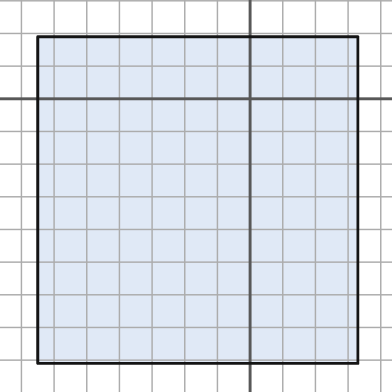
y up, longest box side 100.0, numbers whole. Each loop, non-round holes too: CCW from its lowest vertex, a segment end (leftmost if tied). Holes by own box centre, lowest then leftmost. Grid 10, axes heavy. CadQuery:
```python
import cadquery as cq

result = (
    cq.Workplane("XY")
    .moveTo(-65.0, -81.0)
    .lineTo(33.0, -81.0)
    .lineTo(33.0, 19.0)
    .lineTo(-65.0, 19.0)
    .close()
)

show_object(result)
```